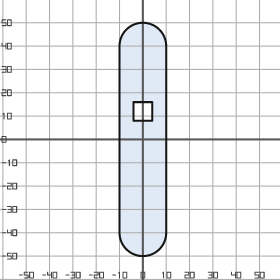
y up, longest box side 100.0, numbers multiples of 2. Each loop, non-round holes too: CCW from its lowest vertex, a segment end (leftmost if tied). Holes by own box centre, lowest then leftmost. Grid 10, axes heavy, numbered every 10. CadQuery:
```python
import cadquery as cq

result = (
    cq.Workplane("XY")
    .moveTo(-10.0, -40.0)
    .threePointArc((0.0, -50.0), (10.0, -40.0))
    .lineTo(10.0, 40.0)
    .threePointArc((0.0, 50.0), (-10.0, 40.0))
    .close()
    .moveTo(-4.0, 8.0)
    .lineTo(4.0, 8.0)
    .lineTo(4.0, 16.0)
    .lineTo(-4.0, 16.0)
    .close()
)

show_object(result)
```